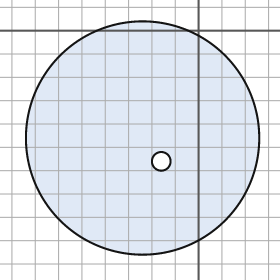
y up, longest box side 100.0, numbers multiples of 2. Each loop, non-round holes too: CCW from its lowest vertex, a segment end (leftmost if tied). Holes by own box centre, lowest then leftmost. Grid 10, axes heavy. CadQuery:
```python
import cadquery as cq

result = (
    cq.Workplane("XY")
    .moveTo(-24.0, -46.0)
    .circle(50.0)
    .moveTo(-16.0, -56.0)
    .circle(4.0)
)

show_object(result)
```